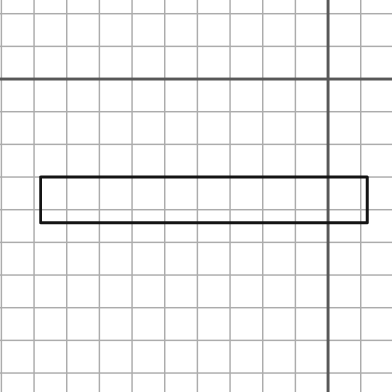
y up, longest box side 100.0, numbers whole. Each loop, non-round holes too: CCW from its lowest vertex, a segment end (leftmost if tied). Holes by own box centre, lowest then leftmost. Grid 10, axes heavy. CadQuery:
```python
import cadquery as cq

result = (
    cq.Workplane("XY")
    .moveTo(-88.0, -44.0)
    .lineTo(12.0, -44.0)
    .lineTo(12.0, -30.0)
    .lineTo(-88.0, -30.0)
    .close()
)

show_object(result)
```